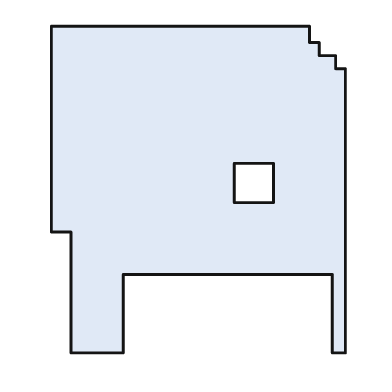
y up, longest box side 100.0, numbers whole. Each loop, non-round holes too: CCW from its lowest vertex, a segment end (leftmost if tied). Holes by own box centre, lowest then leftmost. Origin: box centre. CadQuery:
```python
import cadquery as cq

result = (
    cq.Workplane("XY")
    .moveTo(-39.0, -50.0)
    .lineTo(-23.0, -50.0)
    .lineTo(-23.0, -26.0)
    .lineTo(41.0, -26.0)
    .lineTo(41.0, -50.0)
    .lineTo(45.0, -50.0)
    .lineTo(45.0, 37.0)
    .lineTo(42.0, 37.0)
    .lineTo(42.0, 41.0)
    .lineTo(37.0, 41.0)
    .lineTo(37.0, 45.0)
    .lineTo(34.0, 45.0)
    .lineTo(34.0, 50.0)
    .lineTo(-45.0, 50.0)
    .lineTo(-45.0, -13.0)
    .lineTo(-39.0, -13.0)
    .close()
    .moveTo(11.0, -4.0)
    .lineTo(23.0, -4.0)
    .lineTo(23.0, 8.0)
    .lineTo(11.0, 8.0)
    .close()
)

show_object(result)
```